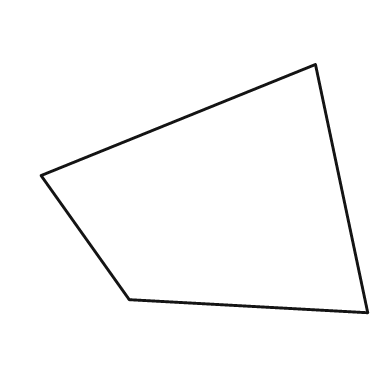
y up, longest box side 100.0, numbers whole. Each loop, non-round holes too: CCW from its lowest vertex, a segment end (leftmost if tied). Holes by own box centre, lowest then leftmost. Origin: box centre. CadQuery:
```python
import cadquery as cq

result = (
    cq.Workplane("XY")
    .moveTo(50.0, -38.0)
    .lineTo(34.0, 38.0)
    .lineTo(-50.0, 4.0)
    .lineTo(-23.0, -34.0)
    .close()
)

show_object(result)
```